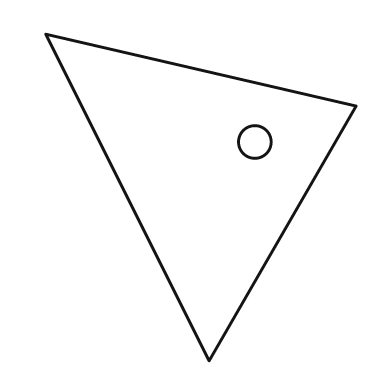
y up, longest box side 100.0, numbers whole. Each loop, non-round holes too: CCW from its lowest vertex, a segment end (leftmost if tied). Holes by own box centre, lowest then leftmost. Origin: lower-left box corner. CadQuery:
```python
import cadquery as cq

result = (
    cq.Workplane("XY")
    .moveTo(50.0, 0.0)
    .lineTo(95.0, 78.0)
    .lineTo(0.0, 100.0)
    .close()
    .moveTo(64.0, 67.0)
    .circle(5.0)
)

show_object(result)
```